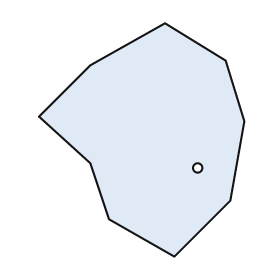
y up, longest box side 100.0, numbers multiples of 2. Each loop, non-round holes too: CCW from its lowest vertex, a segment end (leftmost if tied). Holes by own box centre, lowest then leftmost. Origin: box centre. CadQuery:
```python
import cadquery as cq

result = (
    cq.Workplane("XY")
    .moveTo(14.0, -50.0)
    .lineTo(38.0, -26.0)
    .lineTo(44.0, 8.0)
    .lineTo(36.0, 34.0)
    .lineTo(10.0, 50.0)
    .lineTo(-22.0, 32.0)
    .lineTo(-44.0, 10.0)
    .lineTo(-22.0, -10.0)
    .lineTo(-14.0, -34.0)
    .close()
    .moveTo(24.0, -12.0)
    .circle(2.0)
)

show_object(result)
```